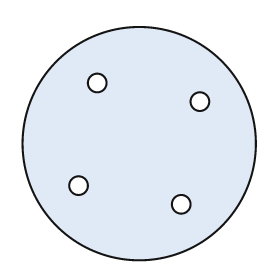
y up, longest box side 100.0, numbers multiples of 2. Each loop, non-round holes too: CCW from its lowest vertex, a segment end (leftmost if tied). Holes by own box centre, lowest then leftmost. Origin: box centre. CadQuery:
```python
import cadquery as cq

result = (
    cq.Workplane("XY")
    .moveTo(0.0, 0.0)
    .circle(50.0)
    .moveTo(18.0, -26.0)
    .circle(4.0)
    .moveTo(-26.0, -18.0)
    .circle(4.0)
    .moveTo(26.0, 18.0)
    .circle(4.0)
    .moveTo(-18.0, 26.0)
    .circle(4.0)
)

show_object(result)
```